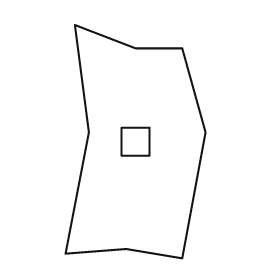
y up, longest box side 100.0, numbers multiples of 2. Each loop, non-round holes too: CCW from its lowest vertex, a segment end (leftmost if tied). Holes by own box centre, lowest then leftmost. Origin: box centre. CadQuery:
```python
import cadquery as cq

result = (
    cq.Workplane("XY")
    .moveTo(20.0, -50.0)
    .lineTo(30.0, 4.0)
    .lineTo(20.0, 40.0)
    .lineTo(0.0, 40.0)
    .lineTo(-26.0, 50.0)
    .lineTo(-20.0, 4.0)
    .lineTo(-30.0, -48.0)
    .lineTo(-4.0, -46.0)
    .close()
    .moveTo(-6.0, -6.0)
    .lineTo(6.0, -6.0)
    .lineTo(6.0, 6.0)
    .lineTo(-6.0, 6.0)
    .close()
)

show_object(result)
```